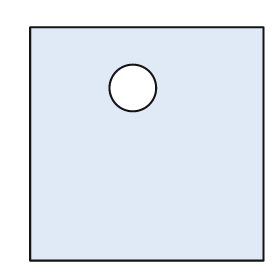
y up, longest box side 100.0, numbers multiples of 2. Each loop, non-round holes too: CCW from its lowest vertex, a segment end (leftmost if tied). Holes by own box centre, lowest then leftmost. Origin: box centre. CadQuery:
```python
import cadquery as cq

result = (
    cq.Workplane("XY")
    .moveTo(-50.0, -50.0)
    .lineTo(50.0, -50.0)
    .lineTo(50.0, 50.0)
    .lineTo(-50.0, 50.0)
    .close()
    .moveTo(-6.0, 24.0)
    .circle(10.0)
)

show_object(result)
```